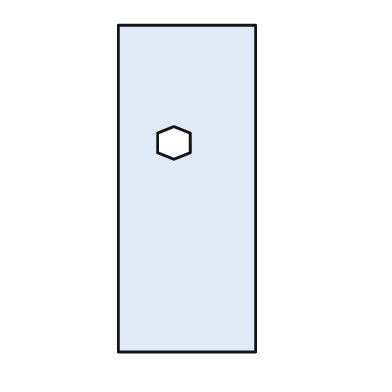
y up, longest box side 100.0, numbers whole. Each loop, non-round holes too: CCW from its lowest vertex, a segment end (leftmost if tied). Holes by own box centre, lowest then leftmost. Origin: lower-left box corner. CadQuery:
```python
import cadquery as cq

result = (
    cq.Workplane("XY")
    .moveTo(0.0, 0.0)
    .lineTo(42.0, 0.0)
    .lineTo(42.0, 100.0)
    .lineTo(0.0, 100.0)
    .close()
    .moveTo(17.0, 59.0)
    .lineTo(22.0, 61.0)
    .lineTo(22.0, 67.0)
    .lineTo(17.0, 69.0)
    .lineTo(12.0, 67.0)
    .lineTo(12.0, 61.0)
    .close()
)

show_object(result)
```